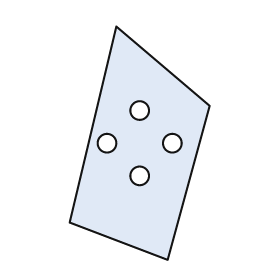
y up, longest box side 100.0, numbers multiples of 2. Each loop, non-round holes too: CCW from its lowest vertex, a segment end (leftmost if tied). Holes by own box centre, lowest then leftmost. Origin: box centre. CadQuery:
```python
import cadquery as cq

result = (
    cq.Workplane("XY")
    .moveTo(12.0, -50.0)
    .lineTo(30.0, 16.0)
    .lineTo(-10.0, 50.0)
    .lineTo(-30.0, -34.0)
    .close()
    .moveTo(0.0, -14.0)
    .circle(4.0)
    .moveTo(-14.0, 0.0)
    .circle(4.0)
    .moveTo(14.0, 0.0)
    .circle(4.0)
    .moveTo(0.0, 14.0)
    .circle(4.0)
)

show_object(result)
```